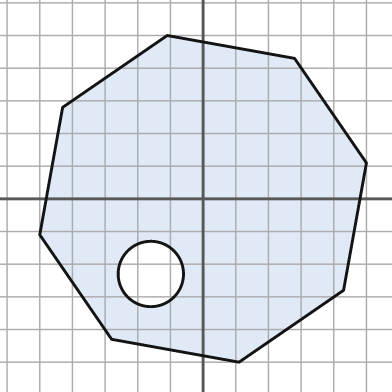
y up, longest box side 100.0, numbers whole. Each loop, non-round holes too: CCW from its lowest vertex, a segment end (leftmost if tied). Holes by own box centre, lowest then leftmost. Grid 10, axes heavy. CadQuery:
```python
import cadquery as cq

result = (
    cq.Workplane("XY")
    .moveTo(11.0, -50.0)
    .lineTo(43.0, -28.0)
    .lineTo(50.0, 11.0)
    .lineTo(28.0, 43.0)
    .lineTo(-11.0, 50.0)
    .lineTo(-43.0, 28.0)
    .lineTo(-50.0, -11.0)
    .lineTo(-28.0, -43.0)
    .close()
    .moveTo(-16.0, -23.0)
    .circle(10.0)
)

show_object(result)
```